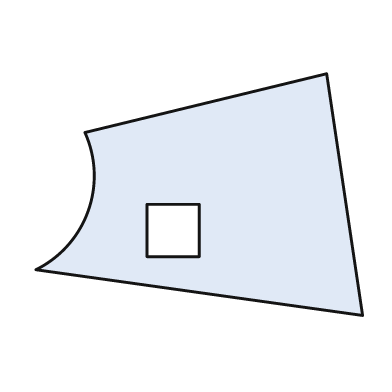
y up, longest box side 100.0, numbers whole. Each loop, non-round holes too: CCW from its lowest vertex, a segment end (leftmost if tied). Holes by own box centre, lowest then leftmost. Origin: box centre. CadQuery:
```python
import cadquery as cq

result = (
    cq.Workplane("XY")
    .moveTo(50.0, -37.0)
    .lineTo(39.0, 37.0)
    .lineTo(-35.0, 19.0)
    .threePointArc((-34.0, -5.0), (-50.0, -23.0))
    .close()
    .moveTo(-16.0, -19.0)
    .lineTo(0.0, -19.0)
    .lineTo(0.0, -3.0)
    .lineTo(-16.0, -3.0)
    .close()
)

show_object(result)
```